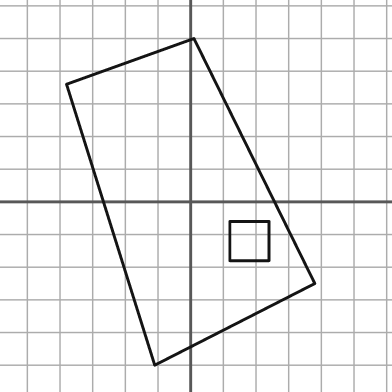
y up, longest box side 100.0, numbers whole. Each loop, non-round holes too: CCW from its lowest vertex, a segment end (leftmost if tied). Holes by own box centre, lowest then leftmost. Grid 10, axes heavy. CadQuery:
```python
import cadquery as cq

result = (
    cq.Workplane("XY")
    .moveTo(-11.0, -50.0)
    .lineTo(38.0, -25.0)
    .lineTo(1.0, 50.0)
    .lineTo(-38.0, 36.0)
    .close()
    .moveTo(12.0, -18.0)
    .lineTo(24.0, -18.0)
    .lineTo(24.0, -6.0)
    .lineTo(12.0, -6.0)
    .close()
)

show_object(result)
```